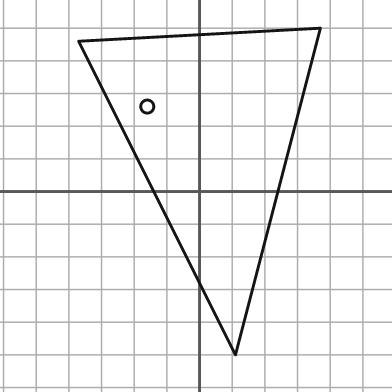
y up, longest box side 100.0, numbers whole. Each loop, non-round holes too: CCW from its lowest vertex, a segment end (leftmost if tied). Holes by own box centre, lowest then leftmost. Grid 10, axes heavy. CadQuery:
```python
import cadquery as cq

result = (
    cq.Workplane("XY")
    .moveTo(11.0, -50.0)
    .lineTo(37.0, 50.0)
    .lineTo(-37.0, 46.0)
    .close()
    .moveTo(-16.0, 26.0)
    .circle(2.0)
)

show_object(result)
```